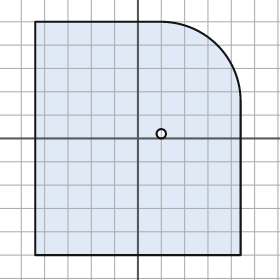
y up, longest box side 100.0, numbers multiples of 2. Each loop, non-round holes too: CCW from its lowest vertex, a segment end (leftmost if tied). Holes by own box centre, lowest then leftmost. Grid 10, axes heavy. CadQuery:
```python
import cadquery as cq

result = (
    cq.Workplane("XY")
    .moveTo(-44.0, -50.0)
    .lineTo(44.0, -50.0)
    .lineTo(44.0, 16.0)
    .threePointArc((34.0, 40.0), (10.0, 50.0))
    .lineTo(-44.0, 50.0)
    .close()
    .moveTo(10.0, 2.0)
    .circle(2.0)
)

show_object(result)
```